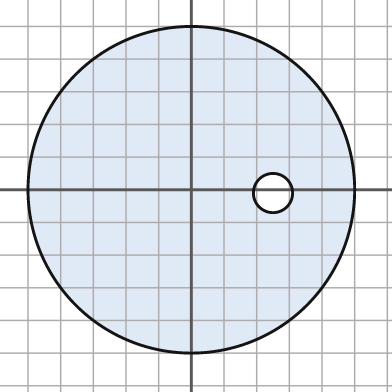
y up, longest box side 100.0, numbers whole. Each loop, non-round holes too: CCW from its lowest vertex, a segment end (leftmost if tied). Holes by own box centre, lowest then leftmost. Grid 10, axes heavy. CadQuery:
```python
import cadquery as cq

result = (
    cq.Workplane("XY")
    .moveTo(0.0, 0.0)
    .circle(50.0)
    .moveTo(25.0, -1.0)
    .circle(6.0)
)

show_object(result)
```